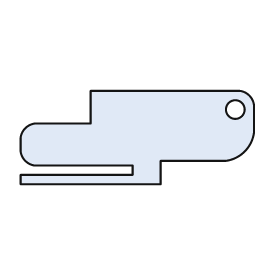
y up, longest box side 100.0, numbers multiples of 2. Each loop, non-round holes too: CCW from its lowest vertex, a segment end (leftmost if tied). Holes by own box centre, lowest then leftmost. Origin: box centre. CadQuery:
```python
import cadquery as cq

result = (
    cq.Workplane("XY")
    .moveTo(-50.0, -20.0)
    .lineTo(10.0, -20.0)
    .lineTo(10.0, -10.0)
    .lineTo(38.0, -10.0)
    .threePointArc((46.0, -6.0), (50.0, 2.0))
    .lineTo(50.0, 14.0)
    .threePointArc((48.0, 18.0), (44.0, 20.0))
    .lineTo(-20.0, 20.0)
    .lineTo(-20.0, 6.0)
    .lineTo(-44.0, 6.0)
    .threePointArc((-48.0, 4.0), (-50.0, 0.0))
    .lineTo(-50.0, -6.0)
    .threePointArc((-48.0, -10.0), (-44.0, -12.0))
    .lineTo(-2.0, -12.0)
    .lineTo(-2.0, -16.0)
    .lineTo(-50.0, -16.0)
    .close()
    .moveTo(42.0, 12.0)
    .circle(4.0)
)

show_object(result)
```